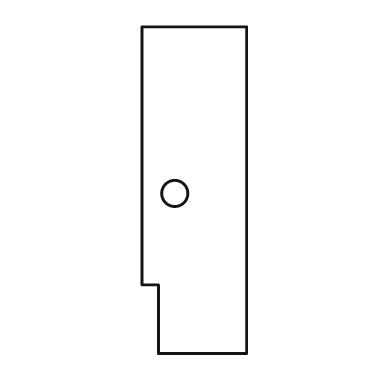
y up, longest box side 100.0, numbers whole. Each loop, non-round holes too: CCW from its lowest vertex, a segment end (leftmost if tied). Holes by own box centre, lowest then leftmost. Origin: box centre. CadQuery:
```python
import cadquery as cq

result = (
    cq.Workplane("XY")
    .moveTo(-11.0, -50.0)
    .lineTo(16.0, -50.0)
    .lineTo(16.0, 50.0)
    .lineTo(-16.0, 50.0)
    .lineTo(-16.0, -29.0)
    .lineTo(-11.0, -29.0)
    .close()
    .moveTo(-6.0, -1.0)
    .circle(4.0)
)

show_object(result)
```